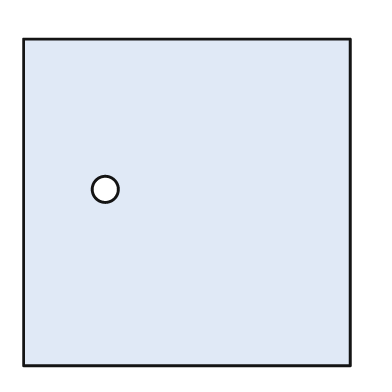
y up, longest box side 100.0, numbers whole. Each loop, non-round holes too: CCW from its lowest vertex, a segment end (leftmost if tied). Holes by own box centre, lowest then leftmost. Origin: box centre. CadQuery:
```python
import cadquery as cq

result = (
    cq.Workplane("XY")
    .moveTo(-50.0, -50.0)
    .lineTo(50.0, -50.0)
    .lineTo(50.0, 50.0)
    .lineTo(-50.0, 50.0)
    .close()
    .moveTo(-25.0, 4.0)
    .circle(4.0)
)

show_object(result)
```